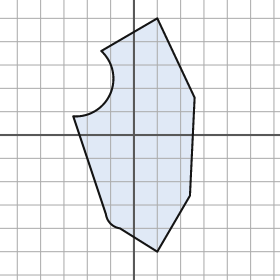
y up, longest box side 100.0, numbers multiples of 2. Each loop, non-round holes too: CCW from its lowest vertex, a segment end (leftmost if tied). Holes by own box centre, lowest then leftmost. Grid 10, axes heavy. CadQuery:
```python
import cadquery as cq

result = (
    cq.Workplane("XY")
    .moveTo(10.0, -50.0)
    .lineTo(24.0, -26.0)
    .lineTo(26.0, 16.0)
    .lineTo(10.0, 50.0)
    .lineTo(-14.0, 36.0)
    .threePointArc((-10.0, 18.0), (-26.0, 8.0))
    .lineTo(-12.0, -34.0)
    .threePointArc((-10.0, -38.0), (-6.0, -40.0))
    .close()
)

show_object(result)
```